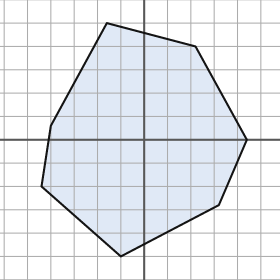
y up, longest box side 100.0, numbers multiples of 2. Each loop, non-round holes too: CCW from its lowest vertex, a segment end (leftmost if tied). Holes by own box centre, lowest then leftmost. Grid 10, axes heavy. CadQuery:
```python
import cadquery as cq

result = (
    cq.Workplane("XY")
    .moveTo(-10.0, -50.0)
    .lineTo(32.0, -28.0)
    .lineTo(44.0, 0.0)
    .lineTo(22.0, 40.0)
    .lineTo(-16.0, 50.0)
    .lineTo(-40.0, 6.0)
    .lineTo(-44.0, -20.0)
    .close()
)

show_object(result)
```